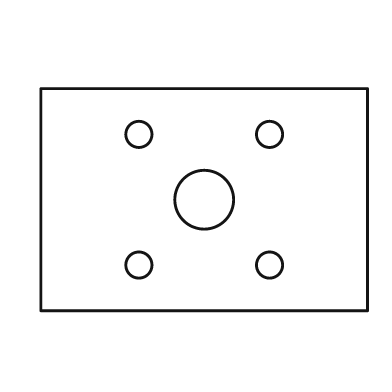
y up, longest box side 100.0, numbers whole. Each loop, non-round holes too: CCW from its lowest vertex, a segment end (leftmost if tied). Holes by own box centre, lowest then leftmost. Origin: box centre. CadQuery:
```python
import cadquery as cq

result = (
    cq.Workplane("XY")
    .moveTo(-50.0, -34.0)
    .lineTo(50.0, -34.0)
    .lineTo(50.0, 34.0)
    .lineTo(-50.0, 34.0)
    .close()
    .moveTo(-20.0, -20.0)
    .circle(4.0)
    .moveTo(20.0, -20.0)
    .circle(4.0)
    .moveTo(0.0, 0.0)
    .circle(9.0)
    .moveTo(-20.0, 20.0)
    .circle(4.0)
    .moveTo(20.0, 20.0)
    .circle(4.0)
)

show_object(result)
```